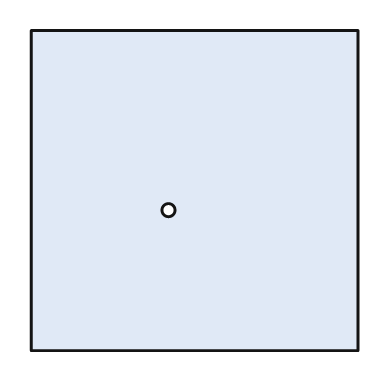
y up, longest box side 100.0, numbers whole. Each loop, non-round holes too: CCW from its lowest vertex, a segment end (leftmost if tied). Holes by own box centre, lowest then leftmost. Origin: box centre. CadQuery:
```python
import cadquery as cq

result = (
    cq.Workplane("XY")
    .moveTo(-50.0, -49.0)
    .lineTo(50.0, -49.0)
    .lineTo(50.0, 49.0)
    .lineTo(-50.0, 49.0)
    .close()
    .moveTo(-8.0, -6.0)
    .circle(2.0)
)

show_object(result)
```